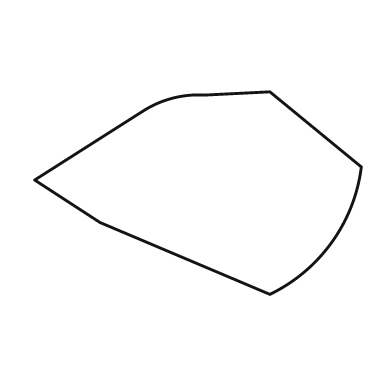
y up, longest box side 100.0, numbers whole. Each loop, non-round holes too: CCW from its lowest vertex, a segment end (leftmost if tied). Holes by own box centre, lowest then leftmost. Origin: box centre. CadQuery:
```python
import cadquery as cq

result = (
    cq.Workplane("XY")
    .moveTo(22.0, -31.0)
    .threePointArc((41.0, -15.0), (50.0, 8.0))
    .lineTo(22.0, 31.0)
    .lineTo(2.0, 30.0)
    .threePointArc((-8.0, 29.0), (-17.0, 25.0))
    .lineTo(-50.0, 4.0)
    .lineTo(-30.0, -9.0)
    .close()
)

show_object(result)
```